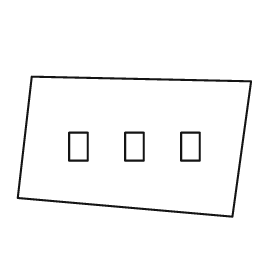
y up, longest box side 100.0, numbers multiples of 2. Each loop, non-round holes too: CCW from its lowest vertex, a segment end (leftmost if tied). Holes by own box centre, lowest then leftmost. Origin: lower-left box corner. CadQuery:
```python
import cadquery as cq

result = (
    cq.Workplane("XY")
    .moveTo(92.0, 0.0)
    .lineTo(100.0, 58.0)
    .lineTo(6.0, 60.0)
    .lineTo(0.0, 8.0)
    .close()
    .moveTo(22.0, 24.0)
    .lineTo(30.0, 24.0)
    .lineTo(30.0, 36.0)
    .lineTo(22.0, 36.0)
    .close()
    .moveTo(46.0, 24.0)
    .lineTo(54.0, 24.0)
    .lineTo(54.0, 36.0)
    .lineTo(46.0, 36.0)
    .close()
    .moveTo(70.0, 24.0)
    .lineTo(78.0, 24.0)
    .lineTo(78.0, 36.0)
    .lineTo(70.0, 36.0)
    .close()
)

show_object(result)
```